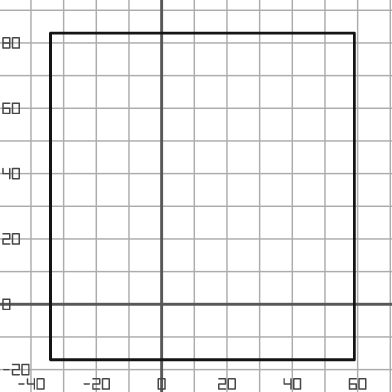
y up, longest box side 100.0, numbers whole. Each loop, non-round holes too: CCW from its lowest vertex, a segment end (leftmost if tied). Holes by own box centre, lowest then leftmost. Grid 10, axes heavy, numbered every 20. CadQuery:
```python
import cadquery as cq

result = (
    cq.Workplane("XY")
    .moveTo(-34.0, -17.0)
    .lineTo(59.0, -17.0)
    .lineTo(59.0, 83.0)
    .lineTo(-34.0, 83.0)
    .close()
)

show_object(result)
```